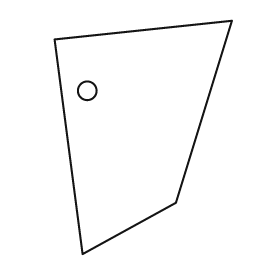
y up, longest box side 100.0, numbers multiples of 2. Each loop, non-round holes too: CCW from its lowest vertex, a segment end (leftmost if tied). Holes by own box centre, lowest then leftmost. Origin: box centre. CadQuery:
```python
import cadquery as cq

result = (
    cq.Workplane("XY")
    .moveTo(-26.0, -50.0)
    .lineTo(14.0, -28.0)
    .lineTo(38.0, 50.0)
    .lineTo(-38.0, 42.0)
    .close()
    .moveTo(-24.0, 20.0)
    .circle(4.0)
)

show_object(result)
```